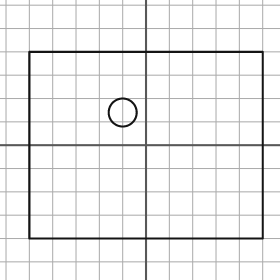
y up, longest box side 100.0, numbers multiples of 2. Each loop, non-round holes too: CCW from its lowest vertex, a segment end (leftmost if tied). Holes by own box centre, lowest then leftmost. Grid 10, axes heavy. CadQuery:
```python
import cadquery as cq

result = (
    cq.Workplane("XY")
    .moveTo(-50.0, -40.0)
    .lineTo(50.0, -40.0)
    .lineTo(50.0, 40.0)
    .lineTo(-50.0, 40.0)
    .close()
    .moveTo(-10.0, 14.0)
    .circle(6.0)
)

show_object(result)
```